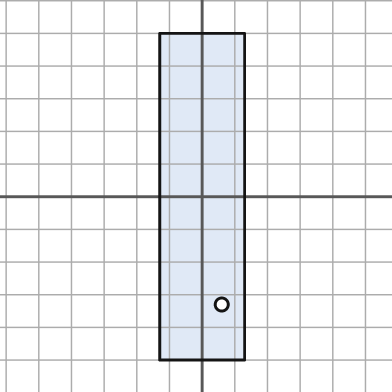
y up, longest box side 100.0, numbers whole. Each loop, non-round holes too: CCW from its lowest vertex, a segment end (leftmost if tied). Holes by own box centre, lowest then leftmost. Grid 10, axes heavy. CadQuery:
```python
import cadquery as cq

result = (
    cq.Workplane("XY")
    .moveTo(-13.0, -50.0)
    .lineTo(13.0, -50.0)
    .lineTo(13.0, 50.0)
    .lineTo(-13.0, 50.0)
    .close()
    .moveTo(6.0, -33.0)
    .circle(2.0)
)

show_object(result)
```